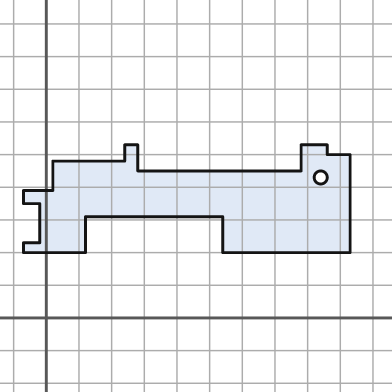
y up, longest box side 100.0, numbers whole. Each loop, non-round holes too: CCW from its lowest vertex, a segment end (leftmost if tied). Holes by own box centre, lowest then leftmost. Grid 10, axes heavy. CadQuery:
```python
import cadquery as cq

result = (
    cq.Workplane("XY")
    .moveTo(-7.0, 20.0)
    .lineTo(12.0, 20.0)
    .lineTo(12.0, 31.0)
    .lineTo(54.0, 31.0)
    .lineTo(54.0, 20.0)
    .lineTo(93.0, 20.0)
    .lineTo(93.0, 50.0)
    .lineTo(86.0, 50.0)
    .lineTo(86.0, 53.0)
    .lineTo(78.0, 53.0)
    .lineTo(78.0, 45.0)
    .lineTo(28.0, 45.0)
    .lineTo(28.0, 53.0)
    .lineTo(24.0, 53.0)
    .lineTo(24.0, 48.0)
    .lineTo(2.0, 48.0)
    .lineTo(2.0, 39.0)
    .lineTo(-7.0, 39.0)
    .lineTo(-7.0, 35.0)
    .lineTo(-2.0, 35.0)
    .lineTo(-2.0, 23.0)
    .lineTo(-7.0, 23.0)
    .close()
    .moveTo(84.0, 43.0)
    .circle(2.0)
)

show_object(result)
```